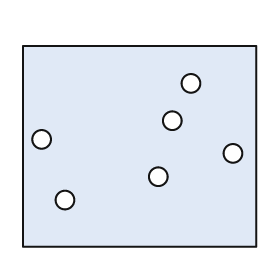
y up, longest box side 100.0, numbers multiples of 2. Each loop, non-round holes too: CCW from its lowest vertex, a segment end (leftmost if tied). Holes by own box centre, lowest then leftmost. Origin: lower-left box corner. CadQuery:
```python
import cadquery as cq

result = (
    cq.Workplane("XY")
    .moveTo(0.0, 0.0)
    .lineTo(100.0, 0.0)
    .lineTo(100.0, 86.0)
    .lineTo(0.0, 86.0)
    .close()
    .moveTo(18.0, 20.0)
    .circle(4.0)
    .moveTo(58.0, 30.0)
    .circle(4.0)
    .moveTo(90.0, 40.0)
    .circle(4.0)
    .moveTo(8.0, 46.0)
    .circle(4.0)
    .moveTo(64.0, 54.0)
    .circle(4.0)
    .moveTo(72.0, 70.0)
    .circle(4.0)
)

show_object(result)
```